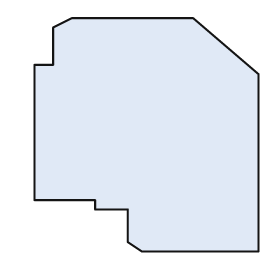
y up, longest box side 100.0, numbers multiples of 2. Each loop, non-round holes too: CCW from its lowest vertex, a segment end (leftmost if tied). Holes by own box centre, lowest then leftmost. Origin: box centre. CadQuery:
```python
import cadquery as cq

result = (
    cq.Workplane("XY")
    .moveTo(-2.0, -50.0)
    .lineTo(48.0, -50.0)
    .lineTo(48.0, 26.0)
    .lineTo(20.0, 50.0)
    .lineTo(-32.0, 50.0)
    .lineTo(-40.0, 46.0)
    .lineTo(-40.0, 30.0)
    .lineTo(-48.0, 30.0)
    .lineTo(-48.0, -28.0)
    .lineTo(-22.0, -28.0)
    .lineTo(-22.0, -32.0)
    .lineTo(-8.0, -32.0)
    .lineTo(-8.0, -46.0)
    .close()
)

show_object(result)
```